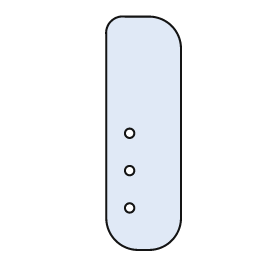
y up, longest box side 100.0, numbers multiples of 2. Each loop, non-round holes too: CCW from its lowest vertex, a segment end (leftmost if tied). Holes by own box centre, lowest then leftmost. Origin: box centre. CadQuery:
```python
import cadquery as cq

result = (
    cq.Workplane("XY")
    .moveTo(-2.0, -50.0)
    .lineTo(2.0, -50.0)
    .threePointArc((12.0, -46.0), (16.0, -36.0))
    .lineTo(16.0, 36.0)
    .threePointArc((12.0, 46.0), (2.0, 50.0))
    .lineTo(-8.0, 50.0)
    .threePointArc((-14.0, 48.0), (-16.0, 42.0))
    .lineTo(-16.0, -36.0)
    .threePointArc((-12.0, -46.0), (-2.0, -50.0))
    .close()
    .moveTo(-6.0, -32.0)
    .circle(2.0)
    .moveTo(-6.0, -16.0)
    .circle(2.0)
    .moveTo(-6.0, 0.0)
    .circle(2.0)
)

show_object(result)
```